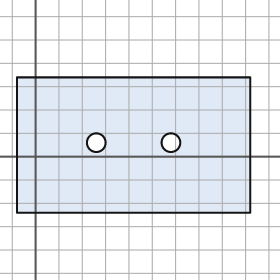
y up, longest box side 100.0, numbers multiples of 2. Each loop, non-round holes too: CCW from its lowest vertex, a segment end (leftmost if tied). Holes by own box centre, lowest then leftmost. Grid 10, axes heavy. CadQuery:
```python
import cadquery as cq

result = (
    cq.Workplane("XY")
    .moveTo(-8.0, -24.0)
    .lineTo(92.0, -24.0)
    .lineTo(92.0, 34.0)
    .lineTo(-8.0, 34.0)
    .close()
    .moveTo(26.0, 6.0)
    .circle(4.0)
    .moveTo(58.0, 6.0)
    .circle(4.0)
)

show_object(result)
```